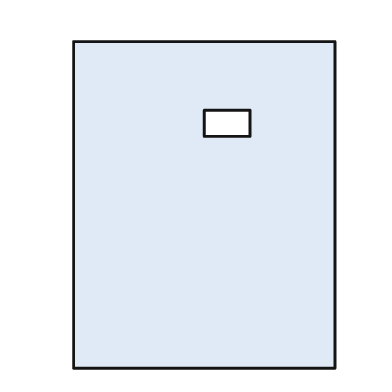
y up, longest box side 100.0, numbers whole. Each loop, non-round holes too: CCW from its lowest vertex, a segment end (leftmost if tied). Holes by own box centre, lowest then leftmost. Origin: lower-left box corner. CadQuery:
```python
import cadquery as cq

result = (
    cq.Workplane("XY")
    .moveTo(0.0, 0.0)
    .lineTo(80.0, 0.0)
    .lineTo(80.0, 100.0)
    .lineTo(0.0, 100.0)
    .close()
    .moveTo(40.0, 71.0)
    .lineTo(54.0, 71.0)
    .lineTo(54.0, 79.0)
    .lineTo(40.0, 79.0)
    .close()
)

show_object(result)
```